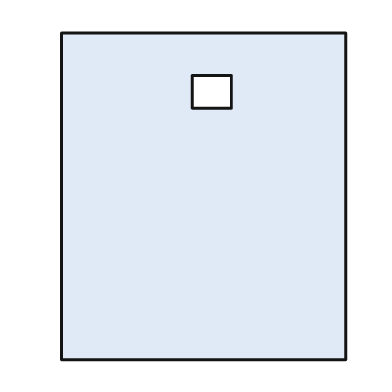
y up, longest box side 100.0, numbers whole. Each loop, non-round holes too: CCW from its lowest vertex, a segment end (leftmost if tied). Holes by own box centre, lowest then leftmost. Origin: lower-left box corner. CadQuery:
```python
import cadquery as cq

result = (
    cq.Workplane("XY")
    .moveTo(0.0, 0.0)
    .lineTo(87.0, 0.0)
    .lineTo(87.0, 100.0)
    .lineTo(0.0, 100.0)
    .close()
    .moveTo(40.0, 77.0)
    .lineTo(52.0, 77.0)
    .lineTo(52.0, 87.0)
    .lineTo(40.0, 87.0)
    .close()
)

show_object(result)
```